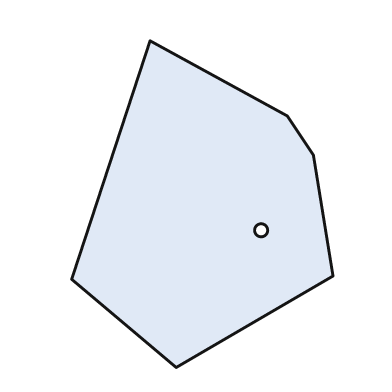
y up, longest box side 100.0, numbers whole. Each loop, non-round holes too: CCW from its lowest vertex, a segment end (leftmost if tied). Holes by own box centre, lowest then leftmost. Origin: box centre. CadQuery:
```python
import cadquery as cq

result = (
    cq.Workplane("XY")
    .moveTo(-8.0, -50.0)
    .lineTo(40.0, -22.0)
    .lineTo(34.0, 15.0)
    .lineTo(26.0, 27.0)
    .lineTo(-16.0, 50.0)
    .lineTo(-40.0, -23.0)
    .close()
    .moveTo(18.0, -8.0)
    .circle(2.0)
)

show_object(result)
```